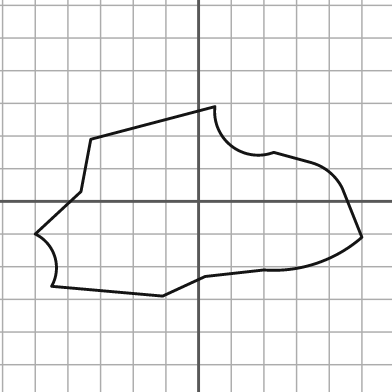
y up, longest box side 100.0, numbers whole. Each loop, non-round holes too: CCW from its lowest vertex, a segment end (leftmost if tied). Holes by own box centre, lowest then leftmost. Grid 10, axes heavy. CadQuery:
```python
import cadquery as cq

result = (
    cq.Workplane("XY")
    .moveTo(-11.0, -29.0)
    .lineTo(2.0, -23.0)
    .lineTo(20.0, -21.0)
    .threePointArc((36.0, -19.0), (50.0, -11.0))
    .lineTo(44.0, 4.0)
    .threePointArc((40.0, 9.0), (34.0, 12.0))
    .lineTo(23.0, 15.0)
    .threePointArc((10.0, 17.0), (5.0, 29.0))
    .lineTo(-33.0, 19.0)
    .lineTo(-36.0, 3.0)
    .lineTo(-50.0, -10.0)
    .threePointArc((-44.0, -17.0), (-45.0, -26.0))
    .close()
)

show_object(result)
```